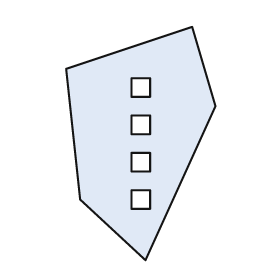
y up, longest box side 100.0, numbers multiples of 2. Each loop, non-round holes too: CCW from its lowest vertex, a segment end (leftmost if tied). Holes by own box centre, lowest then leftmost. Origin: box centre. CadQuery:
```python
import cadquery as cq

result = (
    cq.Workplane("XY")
    .moveTo(2.0, -50.0)
    .lineTo(32.0, 16.0)
    .lineTo(22.0, 50.0)
    .lineTo(-32.0, 32.0)
    .lineTo(-26.0, -24.0)
    .close()
    .moveTo(-4.0, -28.0)
    .lineTo(4.0, -28.0)
    .lineTo(4.0, -20.0)
    .lineTo(-4.0, -20.0)
    .close()
    .moveTo(-4.0, -12.0)
    .lineTo(4.0, -12.0)
    .lineTo(4.0, -4.0)
    .lineTo(-4.0, -4.0)
    .close()
    .moveTo(-4.0, 4.0)
    .lineTo(4.0, 4.0)
    .lineTo(4.0, 12.0)
    .lineTo(-4.0, 12.0)
    .close()
    .moveTo(-4.0, 20.0)
    .lineTo(4.0, 20.0)
    .lineTo(4.0, 28.0)
    .lineTo(-4.0, 28.0)
    .close()
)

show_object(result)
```